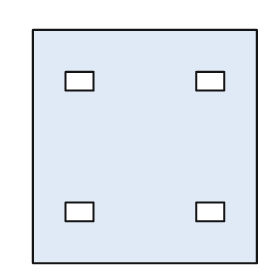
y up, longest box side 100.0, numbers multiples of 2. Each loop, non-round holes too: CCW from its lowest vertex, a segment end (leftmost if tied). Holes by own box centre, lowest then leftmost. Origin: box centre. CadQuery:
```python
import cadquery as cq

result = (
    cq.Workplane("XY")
    .moveTo(-48.0, -50.0)
    .lineTo(48.0, -50.0)
    .lineTo(48.0, 50.0)
    .lineTo(-48.0, 50.0)
    .close()
    .moveTo(-34.0, -32.0)
    .lineTo(-22.0, -32.0)
    .lineTo(-22.0, -24.0)
    .lineTo(-34.0, -24.0)
    .close()
    .moveTo(22.0, -32.0)
    .lineTo(34.0, -32.0)
    .lineTo(34.0, -24.0)
    .lineTo(22.0, -24.0)
    .close()
    .moveTo(-34.0, 24.0)
    .lineTo(-22.0, 24.0)
    .lineTo(-22.0, 32.0)
    .lineTo(-34.0, 32.0)
    .close()
    .moveTo(22.0, 24.0)
    .lineTo(34.0, 24.0)
    .lineTo(34.0, 32.0)
    .lineTo(22.0, 32.0)
    .close()
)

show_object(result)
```